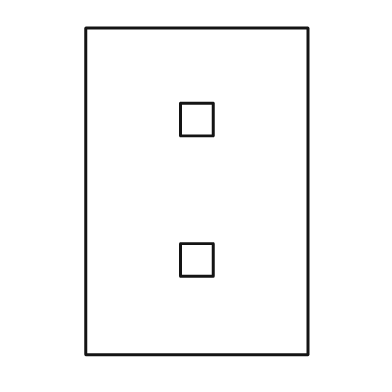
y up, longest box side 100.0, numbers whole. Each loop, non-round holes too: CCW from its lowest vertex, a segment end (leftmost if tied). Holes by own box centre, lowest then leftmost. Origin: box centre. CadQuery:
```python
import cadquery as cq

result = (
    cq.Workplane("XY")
    .moveTo(-34.0, -50.0)
    .lineTo(34.0, -50.0)
    .lineTo(34.0, 50.0)
    .lineTo(-34.0, 50.0)
    .close()
    .moveTo(-5.0, -26.0)
    .lineTo(5.0, -26.0)
    .lineTo(5.0, -16.0)
    .lineTo(-5.0, -16.0)
    .close()
    .moveTo(-5.0, 17.0)
    .lineTo(5.0, 17.0)
    .lineTo(5.0, 27.0)
    .lineTo(-5.0, 27.0)
    .close()
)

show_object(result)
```